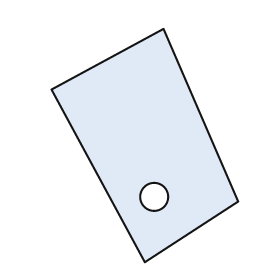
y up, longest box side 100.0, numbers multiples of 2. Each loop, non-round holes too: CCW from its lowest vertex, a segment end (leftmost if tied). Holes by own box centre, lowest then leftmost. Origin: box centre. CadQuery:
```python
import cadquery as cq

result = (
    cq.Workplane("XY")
    .moveTo(0.0, -50.0)
    .lineTo(40.0, -24.0)
    .lineTo(8.0, 50.0)
    .lineTo(-40.0, 24.0)
    .close()
    .moveTo(4.0, -22.0)
    .circle(6.0)
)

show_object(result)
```